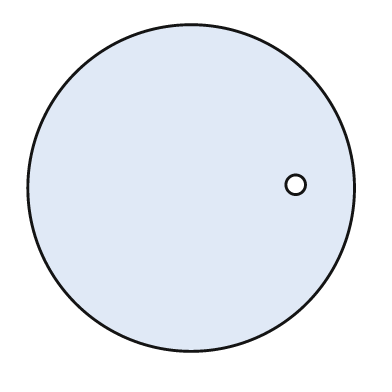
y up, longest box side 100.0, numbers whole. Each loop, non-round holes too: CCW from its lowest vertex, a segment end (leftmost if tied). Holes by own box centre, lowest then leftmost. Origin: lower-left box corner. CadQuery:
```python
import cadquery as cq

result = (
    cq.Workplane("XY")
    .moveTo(50.0, 50.0)
    .circle(50.0)
    .moveTo(82.0, 51.0)
    .circle(3.0)
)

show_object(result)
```